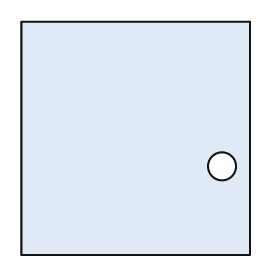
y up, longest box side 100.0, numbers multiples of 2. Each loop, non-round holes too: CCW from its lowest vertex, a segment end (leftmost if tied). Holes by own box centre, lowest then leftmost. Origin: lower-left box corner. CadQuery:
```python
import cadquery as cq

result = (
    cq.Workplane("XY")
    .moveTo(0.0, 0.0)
    .lineTo(98.0, 0.0)
    .lineTo(98.0, 100.0)
    .lineTo(0.0, 100.0)
    .close()
    .moveTo(86.0, 38.0)
    .circle(6.0)
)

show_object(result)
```